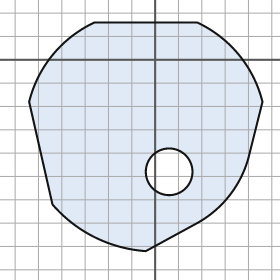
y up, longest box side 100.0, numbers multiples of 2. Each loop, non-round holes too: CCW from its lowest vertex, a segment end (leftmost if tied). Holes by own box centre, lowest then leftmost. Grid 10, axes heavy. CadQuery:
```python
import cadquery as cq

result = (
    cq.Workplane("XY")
    .moveTo(-4.0, -82.0)
    .lineTo(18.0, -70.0)
    .threePointArc((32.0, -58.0), (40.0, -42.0))
    .lineTo(46.0, -18.0)
    .threePointArc((36.0, 2.0), (18.0, 16.0))
    .lineTo(-26.0, 16.0)
    .threePointArc((-44.0, 2.0), (-54.0, -18.0))
    .lineTo(-44.0, -62.0)
    .threePointArc((-26.0, -76.0), (-4.0, -82.0))
    .close()
    .moveTo(6.0, -48.0)
    .circle(10.0)
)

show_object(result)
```